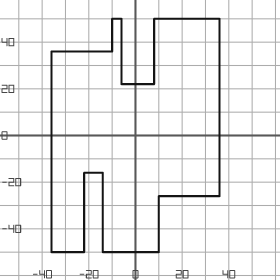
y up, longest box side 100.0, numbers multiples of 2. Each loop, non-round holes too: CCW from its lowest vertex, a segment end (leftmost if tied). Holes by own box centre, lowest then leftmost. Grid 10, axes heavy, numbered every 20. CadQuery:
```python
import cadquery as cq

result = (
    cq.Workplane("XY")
    .moveTo(-36.0, -50.0)
    .lineTo(-22.0, -50.0)
    .lineTo(-22.0, -16.0)
    .lineTo(-14.0, -16.0)
    .lineTo(-14.0, -50.0)
    .lineTo(10.0, -50.0)
    .lineTo(10.0, -26.0)
    .lineTo(36.0, -26.0)
    .lineTo(36.0, 50.0)
    .lineTo(8.0, 50.0)
    .lineTo(8.0, 22.0)
    .lineTo(-6.0, 22.0)
    .lineTo(-6.0, 50.0)
    .lineTo(-10.0, 50.0)
    .lineTo(-10.0, 36.0)
    .lineTo(-36.0, 36.0)
    .close()
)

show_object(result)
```